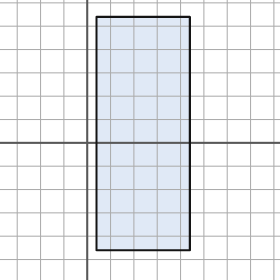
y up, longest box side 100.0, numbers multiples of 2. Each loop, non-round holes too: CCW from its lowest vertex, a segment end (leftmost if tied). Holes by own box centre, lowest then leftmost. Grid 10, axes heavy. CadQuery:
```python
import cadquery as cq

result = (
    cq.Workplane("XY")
    .moveTo(4.0, -46.0)
    .lineTo(44.0, -46.0)
    .lineTo(44.0, 54.0)
    .lineTo(4.0, 54.0)
    .close()
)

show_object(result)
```